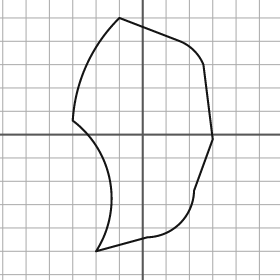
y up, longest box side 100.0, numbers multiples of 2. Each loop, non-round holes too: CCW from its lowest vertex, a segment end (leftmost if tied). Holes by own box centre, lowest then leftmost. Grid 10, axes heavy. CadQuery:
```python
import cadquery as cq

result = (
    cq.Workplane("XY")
    .moveTo(-20.0, -50.0)
    .lineTo(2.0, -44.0)
    .threePointArc((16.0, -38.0), (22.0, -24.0))
    .lineTo(30.0, -2.0)
    .lineTo(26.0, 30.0)
    .threePointArc((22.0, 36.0), (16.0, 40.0))
    .lineTo(-10.0, 50.0)
    .threePointArc((-24.0, 30.0), (-30.0, 6.0))
    .threePointArc((-14.0, -20.0), (-20.0, -50.0))
    .close()
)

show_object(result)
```